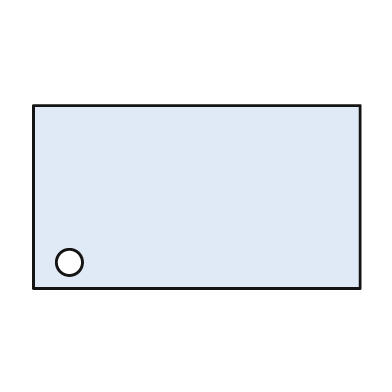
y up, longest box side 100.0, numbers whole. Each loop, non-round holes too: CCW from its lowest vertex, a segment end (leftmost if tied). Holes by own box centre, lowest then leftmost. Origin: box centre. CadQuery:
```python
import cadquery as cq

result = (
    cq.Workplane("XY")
    .moveTo(-50.0, -28.0)
    .lineTo(50.0, -28.0)
    .lineTo(50.0, 28.0)
    .lineTo(-50.0, 28.0)
    .close()
    .moveTo(-39.0, -20.0)
    .circle(4.0)
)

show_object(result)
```